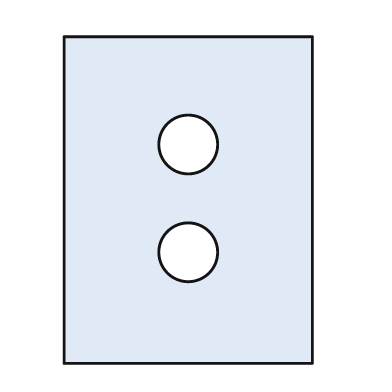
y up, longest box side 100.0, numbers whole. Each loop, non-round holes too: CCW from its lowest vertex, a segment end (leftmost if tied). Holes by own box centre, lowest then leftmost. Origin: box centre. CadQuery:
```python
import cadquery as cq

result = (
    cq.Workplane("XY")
    .moveTo(-38.0, -50.0)
    .lineTo(38.0, -50.0)
    .lineTo(38.0, 50.0)
    .lineTo(-38.0, 50.0)
    .close()
    .moveTo(0.0, -16.0)
    .circle(9.0)
    .moveTo(0.0, 17.0)
    .circle(9.0)
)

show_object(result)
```